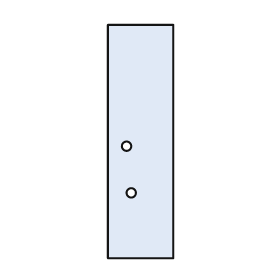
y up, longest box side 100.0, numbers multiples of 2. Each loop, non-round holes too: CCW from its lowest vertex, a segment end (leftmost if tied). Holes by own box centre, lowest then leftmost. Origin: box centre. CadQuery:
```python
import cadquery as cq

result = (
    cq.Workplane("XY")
    .moveTo(-14.0, -50.0)
    .lineTo(14.0, -50.0)
    .lineTo(14.0, 50.0)
    .lineTo(-14.0, 50.0)
    .close()
    .moveTo(-4.0, -22.0)
    .circle(2.0)
    .moveTo(-6.0, -2.0)
    .circle(2.0)
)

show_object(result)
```